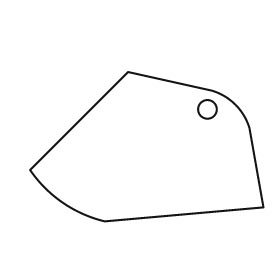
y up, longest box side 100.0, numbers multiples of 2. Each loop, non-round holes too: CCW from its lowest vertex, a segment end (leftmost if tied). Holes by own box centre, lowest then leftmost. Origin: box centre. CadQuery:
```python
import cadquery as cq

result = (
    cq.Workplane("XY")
    .moveTo(-18.0, -32.0)
    .lineTo(50.0, -26.0)
    .lineTo(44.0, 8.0)
    .threePointArc((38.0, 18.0), (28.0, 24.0))
    .lineTo(-8.0, 32.0)
    .lineTo(-50.0, -10.0)
    .threePointArc((-36.0, -24.0), (-18.0, -32.0))
    .close()
    .moveTo(26.0, 16.0)
    .circle(4.0)
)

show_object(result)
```